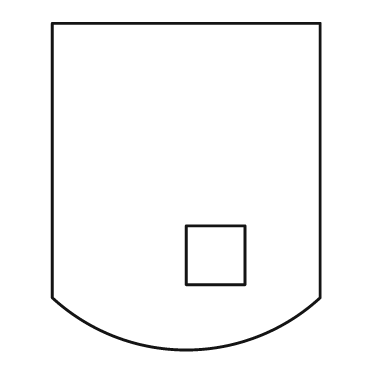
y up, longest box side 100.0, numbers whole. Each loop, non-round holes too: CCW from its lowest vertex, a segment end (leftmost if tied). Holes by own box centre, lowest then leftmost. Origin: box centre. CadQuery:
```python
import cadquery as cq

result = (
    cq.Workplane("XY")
    .moveTo(-41.0, -34.0)
    .threePointArc((0.0, -50.0), (41.0, -34.0))
    .lineTo(41.0, 50.0)
    .lineTo(-41.0, 50.0)
    .close()
    .moveTo(0.0, -30.0)
    .lineTo(18.0, -30.0)
    .lineTo(18.0, -12.0)
    .lineTo(0.0, -12.0)
    .close()
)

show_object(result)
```